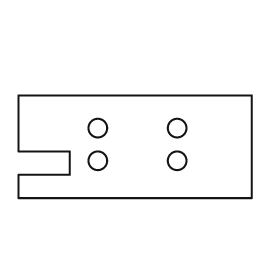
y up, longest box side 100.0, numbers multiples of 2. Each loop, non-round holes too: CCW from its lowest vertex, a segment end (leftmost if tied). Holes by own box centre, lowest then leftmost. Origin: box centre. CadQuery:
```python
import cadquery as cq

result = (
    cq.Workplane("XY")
    .moveTo(-50.0, -22.0)
    .lineTo(50.0, -22.0)
    .lineTo(50.0, 22.0)
    .lineTo(-50.0, 22.0)
    .lineTo(-50.0, -2.0)
    .lineTo(-28.0, -2.0)
    .lineTo(-28.0, -12.0)
    .lineTo(-50.0, -12.0)
    .close()
    .moveTo(-16.0, -6.0)
    .circle(4.0)
    .moveTo(18.0, -6.0)
    .circle(4.0)
    .moveTo(-16.0, 8.0)
    .circle(4.0)
    .moveTo(18.0, 8.0)
    .circle(4.0)
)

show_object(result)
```